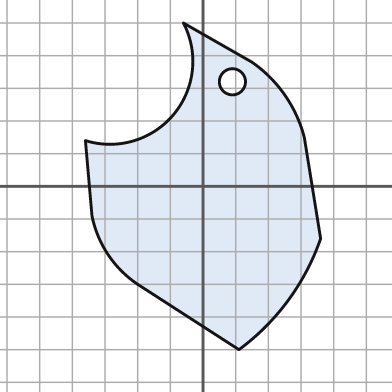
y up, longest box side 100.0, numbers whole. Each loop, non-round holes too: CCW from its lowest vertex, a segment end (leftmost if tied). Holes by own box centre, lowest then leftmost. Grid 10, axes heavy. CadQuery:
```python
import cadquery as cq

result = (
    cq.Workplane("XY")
    .moveTo(11.0, -50.0)
    .threePointArc((26.0, -35.0), (36.0, -16.0))
    .lineTo(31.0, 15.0)
    .threePointArc((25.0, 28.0), (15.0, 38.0))
    .lineTo(-6.0, 50.0)
    .threePointArc((-9.0, 22.0), (-36.0, 14.0))
    .lineTo(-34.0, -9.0)
    .threePointArc((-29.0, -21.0), (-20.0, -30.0))
    .close()
    .moveTo(9.0, 32.0)
    .circle(4.0)
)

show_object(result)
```